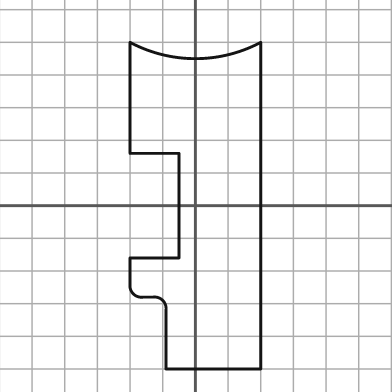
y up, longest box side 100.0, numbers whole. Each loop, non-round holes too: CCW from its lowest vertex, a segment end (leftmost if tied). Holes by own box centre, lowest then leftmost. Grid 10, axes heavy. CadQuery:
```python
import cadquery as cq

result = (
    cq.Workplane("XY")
    .moveTo(-9.0, -50.0)
    .lineTo(20.0, -50.0)
    .lineTo(20.0, 50.0)
    .threePointArc((0.0, 45.0), (-20.0, 50.0))
    .lineTo(-20.0, 16.0)
    .lineTo(-5.0, 16.0)
    .lineTo(-5.0, -16.0)
    .lineTo(-20.0, -16.0)
    .lineTo(-20.0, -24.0)
    .threePointArc((-19.0, -27.0), (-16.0, -28.0))
    .lineTo(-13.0, -28.0)
    .threePointArc((-10.0, -29.0), (-9.0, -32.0))
    .close()
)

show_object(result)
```